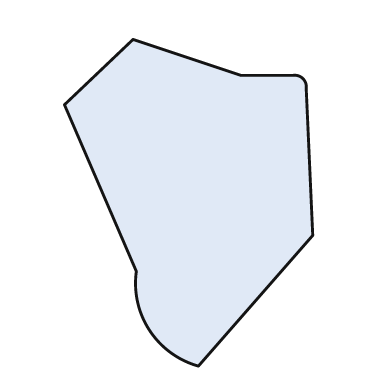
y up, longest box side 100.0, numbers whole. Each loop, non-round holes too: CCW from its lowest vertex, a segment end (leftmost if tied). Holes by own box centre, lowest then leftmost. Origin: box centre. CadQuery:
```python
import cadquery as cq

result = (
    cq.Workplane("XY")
    .moveTo(3.0, -50.0)
    .lineTo(38.0, -10.0)
    .lineTo(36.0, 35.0)
    .threePointArc((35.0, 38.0), (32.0, 39.0))
    .lineTo(16.0, 39.0)
    .lineTo(-17.0, 50.0)
    .lineTo(-38.0, 30.0)
    .lineTo(-16.0, -21.0)
    .threePointArc((-12.0, -39.0), (3.0, -50.0))
    .close()
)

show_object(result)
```